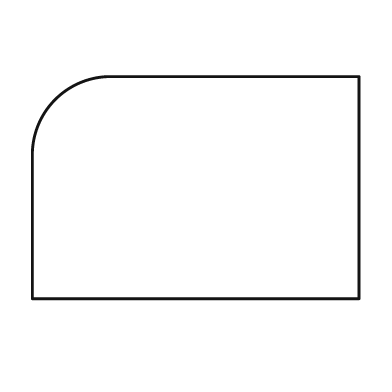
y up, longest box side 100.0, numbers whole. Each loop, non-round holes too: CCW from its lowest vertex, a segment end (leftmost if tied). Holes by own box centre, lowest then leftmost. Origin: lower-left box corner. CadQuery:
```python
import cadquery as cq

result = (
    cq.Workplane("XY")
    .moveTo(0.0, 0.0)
    .lineTo(100.0, 0.0)
    .lineTo(100.0, 68.0)
    .lineTo(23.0, 68.0)
    .threePointArc((7.0, 61.0), (0.0, 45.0))
    .close()
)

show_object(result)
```